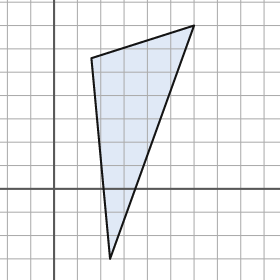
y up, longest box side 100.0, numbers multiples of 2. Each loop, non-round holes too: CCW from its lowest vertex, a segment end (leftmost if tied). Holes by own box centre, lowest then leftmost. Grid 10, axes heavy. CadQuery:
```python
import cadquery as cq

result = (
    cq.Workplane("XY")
    .moveTo(24.0, -30.0)
    .lineTo(60.0, 70.0)
    .lineTo(16.0, 56.0)
    .close()
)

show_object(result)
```